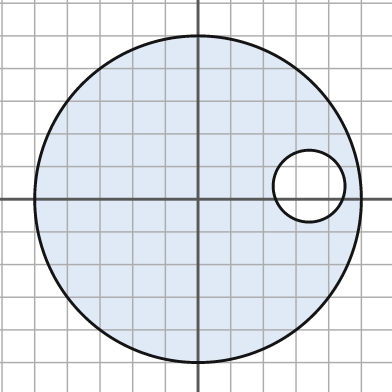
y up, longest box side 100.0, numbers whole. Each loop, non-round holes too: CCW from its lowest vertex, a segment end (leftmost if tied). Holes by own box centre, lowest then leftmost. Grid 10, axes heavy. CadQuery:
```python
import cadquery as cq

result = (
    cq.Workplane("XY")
    .moveTo(0.0, 0.0)
    .circle(50.0)
    .moveTo(34.0, 4.0)
    .circle(11.0)
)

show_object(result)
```